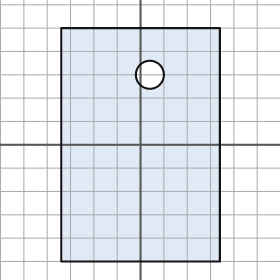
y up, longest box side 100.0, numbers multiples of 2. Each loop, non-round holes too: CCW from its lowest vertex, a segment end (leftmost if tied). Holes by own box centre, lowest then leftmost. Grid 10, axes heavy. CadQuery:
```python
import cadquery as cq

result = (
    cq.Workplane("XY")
    .moveTo(-34.0, -50.0)
    .lineTo(34.0, -50.0)
    .lineTo(34.0, 50.0)
    .lineTo(-34.0, 50.0)
    .close()
    .moveTo(4.0, 30.0)
    .circle(6.0)
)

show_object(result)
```